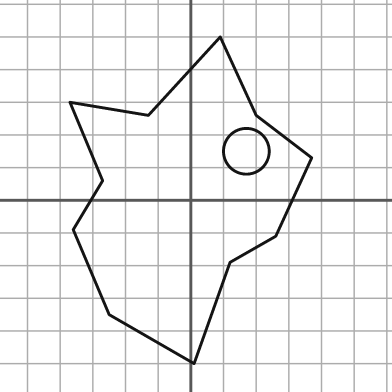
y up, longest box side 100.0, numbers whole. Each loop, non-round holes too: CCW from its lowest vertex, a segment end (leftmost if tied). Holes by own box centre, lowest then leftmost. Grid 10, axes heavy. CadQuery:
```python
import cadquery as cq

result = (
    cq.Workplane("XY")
    .moveTo(1.0, -50.0)
    .lineTo(12.0, -19.0)
    .lineTo(26.0, -11.0)
    .lineTo(37.0, 13.0)
    .lineTo(20.0, 26.0)
    .lineTo(9.0, 50.0)
    .lineTo(-13.0, 26.0)
    .lineTo(-37.0, 30.0)
    .lineTo(-27.0, 6.0)
    .lineTo(-36.0, -9.0)
    .lineTo(-25.0, -35.0)
    .close()
    .moveTo(17.0, 15.0)
    .circle(7.0)
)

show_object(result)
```